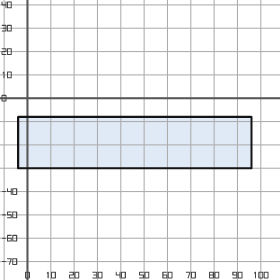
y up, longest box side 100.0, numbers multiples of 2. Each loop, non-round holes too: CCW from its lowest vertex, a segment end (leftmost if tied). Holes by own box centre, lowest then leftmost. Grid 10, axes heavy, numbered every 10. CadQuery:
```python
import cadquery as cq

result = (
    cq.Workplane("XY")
    .moveTo(-4.0, -30.0)
    .lineTo(96.0, -30.0)
    .lineTo(96.0, -8.0)
    .lineTo(-4.0, -8.0)
    .close()
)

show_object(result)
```